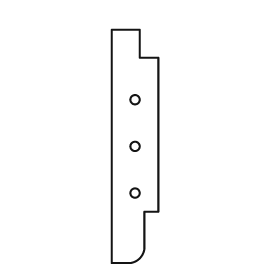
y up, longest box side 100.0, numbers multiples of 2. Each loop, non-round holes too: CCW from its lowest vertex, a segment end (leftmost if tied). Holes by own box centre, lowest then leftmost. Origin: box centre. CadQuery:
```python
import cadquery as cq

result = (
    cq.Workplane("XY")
    .moveTo(-10.0, -50.0)
    .lineTo(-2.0, -50.0)
    .threePointArc((2.0, -48.0), (4.0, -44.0))
    .lineTo(4.0, -28.0)
    .lineTo(10.0, -28.0)
    .lineTo(10.0, 38.0)
    .lineTo(2.0, 38.0)
    .lineTo(2.0, 50.0)
    .lineTo(-10.0, 50.0)
    .close()
    .moveTo(0.0, -20.0)
    .circle(2.0)
    .moveTo(0.0, 0.0)
    .circle(2.0)
    .moveTo(0.0, 20.0)
    .circle(2.0)
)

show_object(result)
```